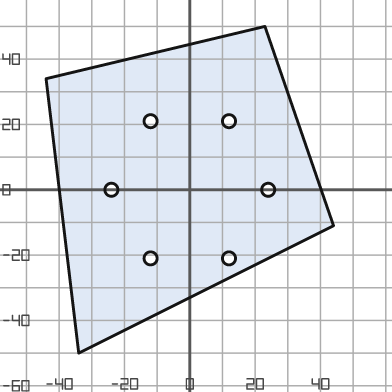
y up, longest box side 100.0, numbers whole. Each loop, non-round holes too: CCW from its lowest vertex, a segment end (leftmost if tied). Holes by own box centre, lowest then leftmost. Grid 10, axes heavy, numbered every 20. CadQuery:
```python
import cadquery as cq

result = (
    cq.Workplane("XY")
    .moveTo(-34.0, -50.0)
    .lineTo(44.0, -11.0)
    .lineTo(23.0, 50.0)
    .lineTo(-44.0, 34.0)
    .close()
    .moveTo(-12.0, -21.0)
    .circle(2.0)
    .moveTo(12.0, -21.0)
    .circle(2.0)
    .moveTo(-24.0, 0.0)
    .circle(2.0)
    .moveTo(24.0, 0.0)
    .circle(2.0)
    .moveTo(-12.0, 21.0)
    .circle(2.0)
    .moveTo(12.0, 21.0)
    .circle(2.0)
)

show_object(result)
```